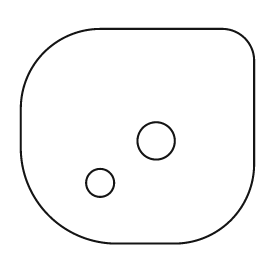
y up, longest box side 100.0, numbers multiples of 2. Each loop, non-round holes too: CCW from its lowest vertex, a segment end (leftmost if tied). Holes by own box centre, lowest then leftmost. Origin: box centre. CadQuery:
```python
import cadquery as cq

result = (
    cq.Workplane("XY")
    .moveTo(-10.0, -46.0)
    .lineTo(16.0, -46.0)
    .threePointArc((40.0, -36.0), (50.0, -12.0))
    .lineTo(50.0, 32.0)
    .threePointArc((46.0, 42.0), (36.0, 46.0))
    .lineTo(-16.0, 46.0)
    .threePointArc((-40.0, 36.0), (-50.0, 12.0))
    .lineTo(-50.0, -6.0)
    .threePointArc((-38.0, -34.0), (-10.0, -46.0))
    .close()
    .moveTo(-16.0, -20.0)
    .circle(6.0)
    .moveTo(8.0, -2.0)
    .circle(8.0)
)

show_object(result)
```